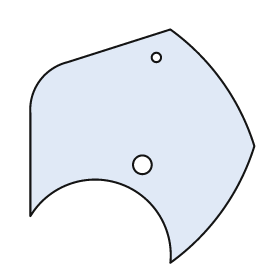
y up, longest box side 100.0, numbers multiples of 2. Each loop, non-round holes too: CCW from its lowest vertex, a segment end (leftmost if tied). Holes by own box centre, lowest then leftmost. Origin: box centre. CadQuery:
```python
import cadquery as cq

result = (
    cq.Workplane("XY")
    .moveTo(12.0, -50.0)
    .threePointArc((34.0, -28.0), (48.0, 0.0))
    .threePointArc((34.0, 28.0), (12.0, 50.0))
    .lineTo(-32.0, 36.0)
    .threePointArc((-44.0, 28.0), (-48.0, 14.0))
    .lineTo(-48.0, -30.0)
    .threePointArc((-10.0, -16.0), (12.0, -50.0))
    .close()
    .moveTo(0.0, -8.0)
    .circle(4.0)
    .moveTo(6.0, 38.0)
    .circle(2.0)
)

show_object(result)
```